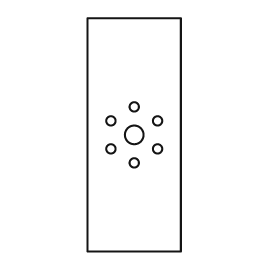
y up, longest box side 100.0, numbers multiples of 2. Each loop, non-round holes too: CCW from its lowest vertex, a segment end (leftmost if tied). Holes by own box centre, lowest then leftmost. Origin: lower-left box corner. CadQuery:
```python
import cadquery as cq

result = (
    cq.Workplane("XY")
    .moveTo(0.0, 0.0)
    .lineTo(40.0, 0.0)
    .lineTo(40.0, 100.0)
    .lineTo(0.0, 100.0)
    .close()
    .moveTo(20.0, 38.0)
    .circle(2.0)
    .moveTo(10.0, 44.0)
    .circle(2.0)
    .moveTo(30.0, 44.0)
    .circle(2.0)
    .moveTo(20.0, 50.0)
    .circle(4.0)
    .moveTo(10.0, 56.0)
    .circle(2.0)
    .moveTo(30.0, 56.0)
    .circle(2.0)
    .moveTo(20.0, 62.0)
    .circle(2.0)
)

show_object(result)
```